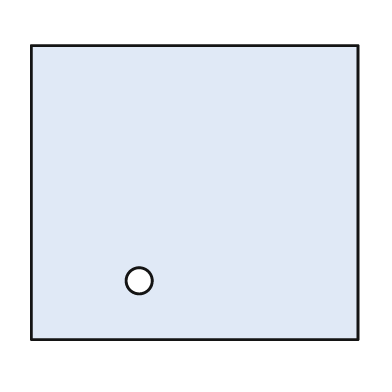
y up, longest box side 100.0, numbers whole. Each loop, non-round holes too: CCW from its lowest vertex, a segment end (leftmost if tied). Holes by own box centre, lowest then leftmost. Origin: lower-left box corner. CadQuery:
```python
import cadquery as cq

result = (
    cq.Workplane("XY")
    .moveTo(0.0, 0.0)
    .lineTo(100.0, 0.0)
    .lineTo(100.0, 90.0)
    .lineTo(0.0, 90.0)
    .close()
    .moveTo(33.0, 18.0)
    .circle(4.0)
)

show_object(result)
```